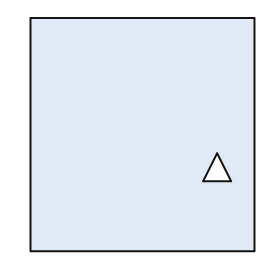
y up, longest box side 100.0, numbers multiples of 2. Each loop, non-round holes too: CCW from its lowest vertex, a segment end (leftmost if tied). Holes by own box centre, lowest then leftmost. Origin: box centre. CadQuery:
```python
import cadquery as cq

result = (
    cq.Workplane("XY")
    .moveTo(-48.0, -50.0)
    .lineTo(48.0, -50.0)
    .lineTo(48.0, 50.0)
    .lineTo(-48.0, 50.0)
    .close()
    .moveTo(26.0, -20.0)
    .lineTo(38.0, -20.0)
    .lineTo(32.0, -8.0)
    .close()
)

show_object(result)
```